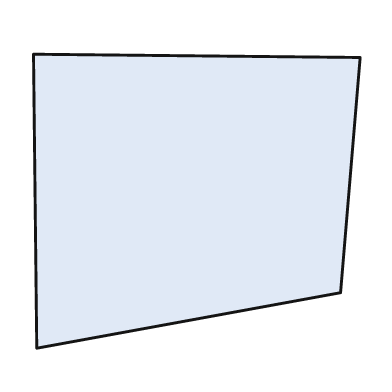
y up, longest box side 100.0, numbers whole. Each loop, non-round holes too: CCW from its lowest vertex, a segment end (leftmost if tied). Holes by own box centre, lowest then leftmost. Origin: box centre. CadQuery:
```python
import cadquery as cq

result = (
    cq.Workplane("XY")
    .moveTo(-49.0, -45.0)
    .lineTo(44.0, -28.0)
    .lineTo(50.0, 44.0)
    .lineTo(-50.0, 45.0)
    .close()
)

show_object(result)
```